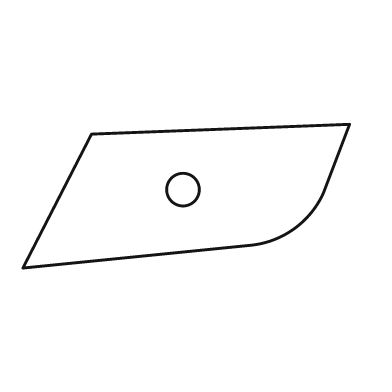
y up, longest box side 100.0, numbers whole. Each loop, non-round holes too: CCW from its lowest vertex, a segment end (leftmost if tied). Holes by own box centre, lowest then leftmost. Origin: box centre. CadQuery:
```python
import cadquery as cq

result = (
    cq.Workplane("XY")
    .moveTo(-50.0, -22.0)
    .lineTo(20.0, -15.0)
    .threePointArc((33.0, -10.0), (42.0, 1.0))
    .lineTo(50.0, 22.0)
    .lineTo(-29.0, 19.0)
    .close()
    .moveTo(-1.0, 2.0)
    .circle(5.0)
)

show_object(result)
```